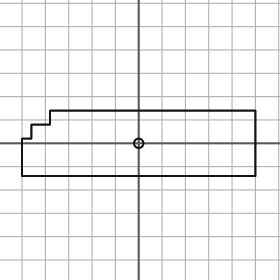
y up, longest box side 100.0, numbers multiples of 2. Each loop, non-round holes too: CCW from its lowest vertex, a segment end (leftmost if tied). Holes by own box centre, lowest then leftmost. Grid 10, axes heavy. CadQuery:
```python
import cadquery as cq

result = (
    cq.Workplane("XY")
    .moveTo(-50.0, -14.0)
    .lineTo(50.0, -14.0)
    .lineTo(50.0, 14.0)
    .lineTo(-38.0, 14.0)
    .lineTo(-38.0, 8.0)
    .lineTo(-46.0, 8.0)
    .lineTo(-46.0, 2.0)
    .lineTo(-50.0, 2.0)
    .close()
    .moveTo(0.0, 0.0)
    .circle(2.0)
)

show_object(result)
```